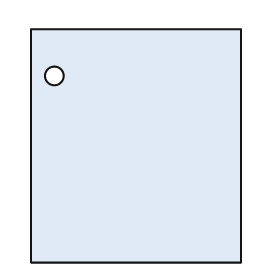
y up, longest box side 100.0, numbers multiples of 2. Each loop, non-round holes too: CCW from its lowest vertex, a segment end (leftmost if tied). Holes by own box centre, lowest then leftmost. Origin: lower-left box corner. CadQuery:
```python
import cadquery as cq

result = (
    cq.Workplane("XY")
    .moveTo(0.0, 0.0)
    .lineTo(90.0, 0.0)
    .lineTo(90.0, 100.0)
    .lineTo(0.0, 100.0)
    .close()
    .moveTo(10.0, 80.0)
    .circle(4.0)
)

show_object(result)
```